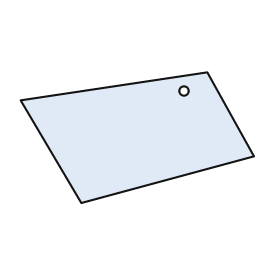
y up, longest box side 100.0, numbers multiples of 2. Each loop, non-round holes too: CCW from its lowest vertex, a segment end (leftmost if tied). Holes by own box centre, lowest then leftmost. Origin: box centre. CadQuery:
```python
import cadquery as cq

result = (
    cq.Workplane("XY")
    .moveTo(-24.0, -28.0)
    .lineTo(50.0, -8.0)
    .lineTo(30.0, 28.0)
    .lineTo(-50.0, 16.0)
    .close()
    .moveTo(20.0, 20.0)
    .circle(2.0)
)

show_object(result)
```